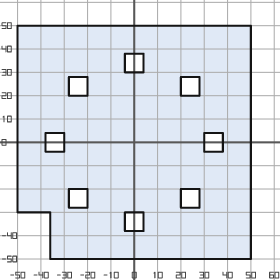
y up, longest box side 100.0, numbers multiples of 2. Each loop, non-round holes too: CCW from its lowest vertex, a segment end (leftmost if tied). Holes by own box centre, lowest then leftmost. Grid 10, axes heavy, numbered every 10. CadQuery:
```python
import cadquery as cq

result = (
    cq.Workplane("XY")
    .moveTo(-36.0, -50.0)
    .lineTo(50.0, -50.0)
    .lineTo(50.0, 50.0)
    .lineTo(-50.0, 50.0)
    .lineTo(-50.0, -30.0)
    .lineTo(-36.0, -30.0)
    .close()
    .moveTo(-4.0, -38.0)
    .lineTo(4.0, -38.0)
    .lineTo(4.0, -30.0)
    .lineTo(-4.0, -30.0)
    .close()
    .moveTo(-28.0, -28.0)
    .lineTo(-20.0, -28.0)
    .lineTo(-20.0, -20.0)
    .lineTo(-28.0, -20.0)
    .close()
    .moveTo(20.0, -28.0)
    .lineTo(28.0, -28.0)
    .lineTo(28.0, -20.0)
    .lineTo(20.0, -20.0)
    .close()
    .moveTo(-38.0, -4.0)
    .lineTo(-30.0, -4.0)
    .lineTo(-30.0, 4.0)
    .lineTo(-38.0, 4.0)
    .close()
    .moveTo(30.0, -4.0)
    .lineTo(38.0, -4.0)
    .lineTo(38.0, 4.0)
    .lineTo(30.0, 4.0)
    .close()
    .moveTo(-28.0, 20.0)
    .lineTo(-20.0, 20.0)
    .lineTo(-20.0, 28.0)
    .lineTo(-28.0, 28.0)
    .close()
    .moveTo(20.0, 20.0)
    .lineTo(28.0, 20.0)
    .lineTo(28.0, 28.0)
    .lineTo(20.0, 28.0)
    .close()
    .moveTo(-4.0, 30.0)
    .lineTo(4.0, 30.0)
    .lineTo(4.0, 38.0)
    .lineTo(-4.0, 38.0)
    .close()
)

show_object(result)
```